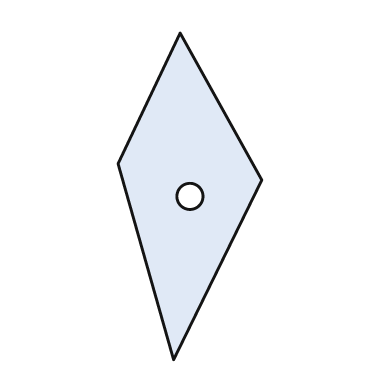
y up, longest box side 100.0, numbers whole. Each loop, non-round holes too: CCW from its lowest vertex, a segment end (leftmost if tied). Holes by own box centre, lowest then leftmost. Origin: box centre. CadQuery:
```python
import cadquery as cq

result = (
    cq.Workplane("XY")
    .moveTo(-5.0, -50.0)
    .lineTo(22.0, 5.0)
    .lineTo(-3.0, 50.0)
    .lineTo(-22.0, 10.0)
    .close()
    .moveTo(0.0, 0.0)
    .circle(4.0)
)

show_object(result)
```